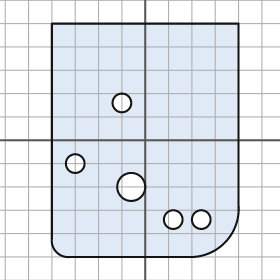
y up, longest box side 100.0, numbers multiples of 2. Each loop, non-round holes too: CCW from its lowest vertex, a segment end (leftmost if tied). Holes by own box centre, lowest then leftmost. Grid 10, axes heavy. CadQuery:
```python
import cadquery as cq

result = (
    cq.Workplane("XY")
    .moveTo(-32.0, -50.0)
    .lineTo(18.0, -50.0)
    .threePointArc((34.0, -44.0), (40.0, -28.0))
    .lineTo(40.0, 50.0)
    .lineTo(-40.0, 50.0)
    .lineTo(-40.0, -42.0)
    .threePointArc((-38.0, -48.0), (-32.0, -50.0))
    .close()
    .moveTo(12.0, -34.0)
    .circle(4.0)
    .moveTo(24.0, -34.0)
    .circle(4.0)
    .moveTo(-6.0, -20.0)
    .circle(6.0)
    .moveTo(-30.0, -10.0)
    .circle(4.0)
    .moveTo(-10.0, 16.0)
    .circle(4.0)
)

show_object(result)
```